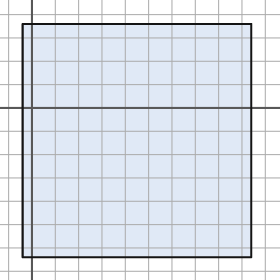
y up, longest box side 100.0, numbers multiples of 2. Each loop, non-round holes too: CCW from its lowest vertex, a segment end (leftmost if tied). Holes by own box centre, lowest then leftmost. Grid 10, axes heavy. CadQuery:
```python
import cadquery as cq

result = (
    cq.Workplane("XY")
    .moveTo(-4.0, -64.0)
    .lineTo(94.0, -64.0)
    .lineTo(94.0, 36.0)
    .lineTo(-4.0, 36.0)
    .close()
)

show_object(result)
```